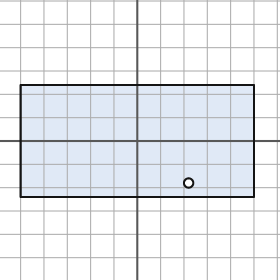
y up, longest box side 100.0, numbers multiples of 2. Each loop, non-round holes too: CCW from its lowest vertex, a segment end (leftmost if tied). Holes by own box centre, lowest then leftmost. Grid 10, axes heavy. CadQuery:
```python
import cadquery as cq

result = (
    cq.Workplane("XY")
    .moveTo(-50.0, -24.0)
    .lineTo(50.0, -24.0)
    .lineTo(50.0, 24.0)
    .lineTo(-50.0, 24.0)
    .close()
    .moveTo(22.0, -18.0)
    .circle(2.0)
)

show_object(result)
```